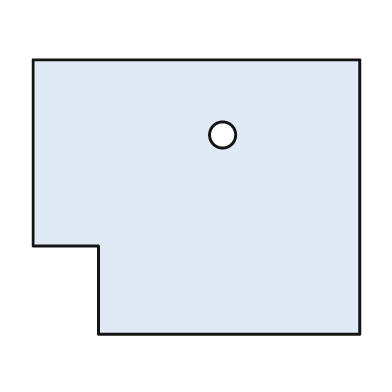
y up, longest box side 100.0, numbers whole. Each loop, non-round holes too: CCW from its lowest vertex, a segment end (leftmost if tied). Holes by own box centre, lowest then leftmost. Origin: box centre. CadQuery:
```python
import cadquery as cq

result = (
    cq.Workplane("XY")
    .moveTo(-30.0, -42.0)
    .lineTo(50.0, -42.0)
    .lineTo(50.0, 42.0)
    .lineTo(-50.0, 42.0)
    .lineTo(-50.0, -15.0)
    .lineTo(-30.0, -15.0)
    .close()
    .moveTo(8.0, 19.0)
    .circle(4.0)
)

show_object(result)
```